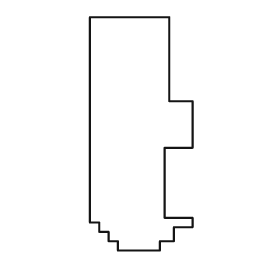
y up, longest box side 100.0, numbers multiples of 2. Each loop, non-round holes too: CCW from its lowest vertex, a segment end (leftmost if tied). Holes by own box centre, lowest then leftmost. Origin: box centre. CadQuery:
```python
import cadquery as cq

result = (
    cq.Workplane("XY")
    .moveTo(-10.0, -50.0)
    .lineTo(8.0, -50.0)
    .lineTo(8.0, -46.0)
    .lineTo(14.0, -46.0)
    .lineTo(14.0, -40.0)
    .lineTo(22.0, -40.0)
    .lineTo(22.0, -36.0)
    .lineTo(10.0, -36.0)
    .lineTo(10.0, -6.0)
    .lineTo(22.0, -6.0)
    .lineTo(22.0, 14.0)
    .lineTo(12.0, 14.0)
    .lineTo(12.0, 50.0)
    .lineTo(-22.0, 50.0)
    .lineTo(-22.0, -38.0)
    .lineTo(-18.0, -38.0)
    .lineTo(-18.0, -42.0)
    .lineTo(-14.0, -42.0)
    .lineTo(-14.0, -46.0)
    .lineTo(-10.0, -46.0)
    .close()
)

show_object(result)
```